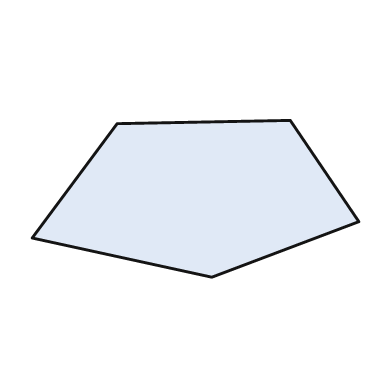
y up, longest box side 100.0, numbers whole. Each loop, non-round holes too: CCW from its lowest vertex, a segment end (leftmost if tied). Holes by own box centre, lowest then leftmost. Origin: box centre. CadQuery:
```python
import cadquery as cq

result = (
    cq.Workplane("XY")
    .moveTo(5.0, -24.0)
    .lineTo(50.0, -7.0)
    .lineTo(29.0, 24.0)
    .lineTo(-24.0, 23.0)
    .lineTo(-50.0, -12.0)
    .close()
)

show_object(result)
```